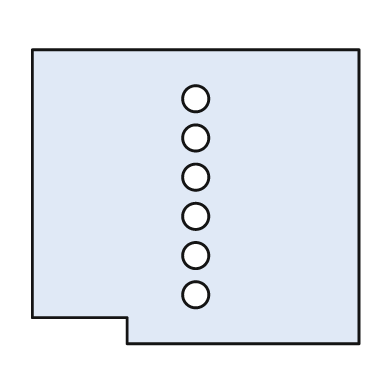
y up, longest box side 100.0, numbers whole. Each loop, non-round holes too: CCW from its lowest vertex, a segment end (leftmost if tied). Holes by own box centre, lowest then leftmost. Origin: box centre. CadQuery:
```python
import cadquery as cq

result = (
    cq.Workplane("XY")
    .moveTo(-21.0, -45.0)
    .lineTo(50.0, -45.0)
    .lineTo(50.0, 45.0)
    .lineTo(-50.0, 45.0)
    .lineTo(-50.0, -37.0)
    .lineTo(-21.0, -37.0)
    .close()
    .moveTo(0.0, -30.0)
    .circle(4.0)
    .moveTo(0.0, -18.0)
    .circle(4.0)
    .moveTo(0.0, -6.0)
    .circle(4.0)
    .moveTo(0.0, 6.0)
    .circle(4.0)
    .moveTo(0.0, 18.0)
    .circle(4.0)
    .moveTo(0.0, 30.0)
    .circle(4.0)
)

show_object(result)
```